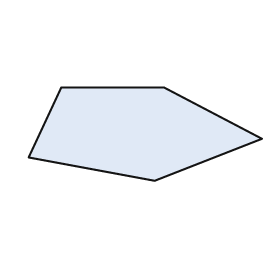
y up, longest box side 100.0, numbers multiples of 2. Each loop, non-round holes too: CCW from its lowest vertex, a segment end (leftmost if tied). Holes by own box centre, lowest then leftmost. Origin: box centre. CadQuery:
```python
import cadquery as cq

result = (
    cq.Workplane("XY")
    .moveTo(4.0, -20.0)
    .lineTo(50.0, -2.0)
    .lineTo(8.0, 20.0)
    .lineTo(-36.0, 20.0)
    .lineTo(-50.0, -10.0)
    .close()
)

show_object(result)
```